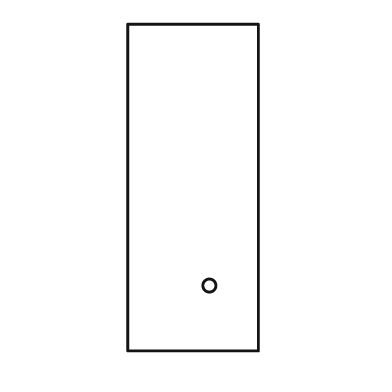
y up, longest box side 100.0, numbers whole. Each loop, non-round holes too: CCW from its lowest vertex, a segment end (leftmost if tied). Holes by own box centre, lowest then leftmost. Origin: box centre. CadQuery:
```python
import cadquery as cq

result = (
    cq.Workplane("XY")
    .moveTo(-20.0, -50.0)
    .lineTo(20.0, -50.0)
    .lineTo(20.0, 50.0)
    .lineTo(-20.0, 50.0)
    .close()
    .moveTo(5.0, -30.0)
    .circle(2.0)
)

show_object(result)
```